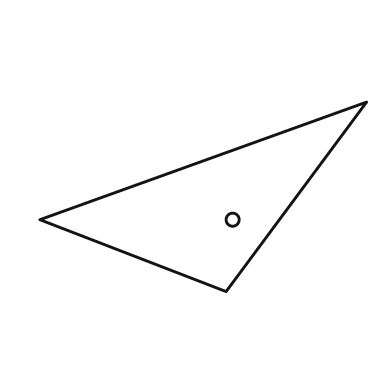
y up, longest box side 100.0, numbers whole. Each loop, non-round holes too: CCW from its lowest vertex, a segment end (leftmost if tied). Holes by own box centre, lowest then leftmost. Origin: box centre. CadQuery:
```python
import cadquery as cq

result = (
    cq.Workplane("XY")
    .moveTo(7.0, -29.0)
    .lineTo(50.0, 29.0)
    .lineTo(-50.0, -7.0)
    .close()
    .moveTo(9.0, -7.0)
    .circle(2.0)
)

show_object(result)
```